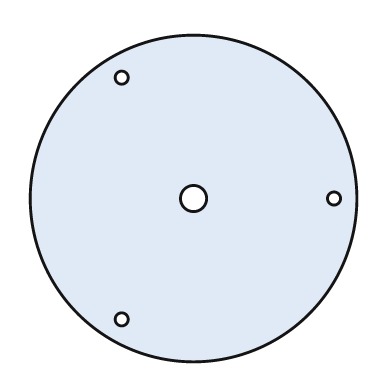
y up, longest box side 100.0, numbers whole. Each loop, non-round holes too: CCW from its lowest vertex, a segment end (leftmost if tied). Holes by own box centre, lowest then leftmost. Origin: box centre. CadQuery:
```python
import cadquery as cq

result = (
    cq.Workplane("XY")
    .moveTo(0.0, 0.0)
    .circle(50.0)
    .moveTo(-22.0, -37.0)
    .circle(2.0)
    .moveTo(0.0, 0.0)
    .circle(4.0)
    .moveTo(43.0, 0.0)
    .circle(2.0)
    .moveTo(-22.0, 37.0)
    .circle(2.0)
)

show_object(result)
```